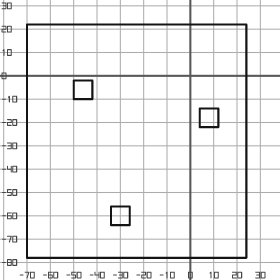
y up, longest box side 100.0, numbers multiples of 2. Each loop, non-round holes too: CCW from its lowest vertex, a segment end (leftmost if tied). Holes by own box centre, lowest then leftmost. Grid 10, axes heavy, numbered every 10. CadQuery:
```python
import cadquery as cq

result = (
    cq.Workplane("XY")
    .moveTo(-70.0, -78.0)
    .lineTo(24.0, -78.0)
    .lineTo(24.0, 22.0)
    .lineTo(-70.0, 22.0)
    .close()
    .moveTo(-34.0, -64.0)
    .lineTo(-26.0, -64.0)
    .lineTo(-26.0, -56.0)
    .lineTo(-34.0, -56.0)
    .close()
    .moveTo(4.0, -22.0)
    .lineTo(12.0, -22.0)
    .lineTo(12.0, -14.0)
    .lineTo(4.0, -14.0)
    .close()
    .moveTo(-50.0, -10.0)
    .lineTo(-42.0, -10.0)
    .lineTo(-42.0, -2.0)
    .lineTo(-50.0, -2.0)
    .close()
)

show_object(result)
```